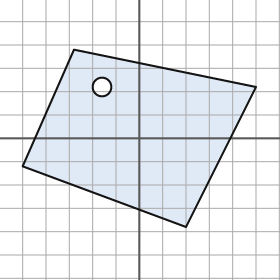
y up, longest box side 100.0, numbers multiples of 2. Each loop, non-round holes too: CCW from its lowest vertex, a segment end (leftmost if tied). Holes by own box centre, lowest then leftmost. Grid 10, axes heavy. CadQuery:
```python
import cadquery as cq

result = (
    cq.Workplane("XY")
    .moveTo(20.0, -38.0)
    .lineTo(50.0, 22.0)
    .lineTo(-28.0, 38.0)
    .lineTo(-50.0, -12.0)
    .close()
    .moveTo(-16.0, 22.0)
    .circle(4.0)
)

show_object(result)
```